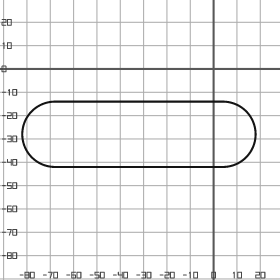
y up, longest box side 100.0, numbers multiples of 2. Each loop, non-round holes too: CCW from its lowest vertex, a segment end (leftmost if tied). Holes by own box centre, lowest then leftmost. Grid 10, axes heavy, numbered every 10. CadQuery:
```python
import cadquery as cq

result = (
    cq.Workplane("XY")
    .moveTo(-68.0, -42.0)
    .lineTo(4.0, -42.0)
    .threePointArc((18.0, -28.0), (4.0, -14.0))
    .lineTo(-68.0, -14.0)
    .threePointArc((-82.0, -28.0), (-68.0, -42.0))
    .close()
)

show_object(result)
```